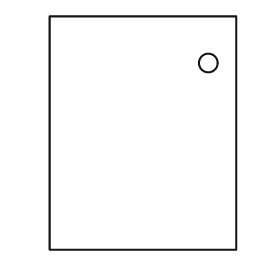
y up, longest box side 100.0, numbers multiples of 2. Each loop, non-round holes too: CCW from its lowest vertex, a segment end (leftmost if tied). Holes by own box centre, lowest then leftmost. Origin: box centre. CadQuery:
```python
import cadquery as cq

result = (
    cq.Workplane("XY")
    .moveTo(-40.0, -50.0)
    .lineTo(40.0, -50.0)
    .lineTo(40.0, 50.0)
    .lineTo(-40.0, 50.0)
    .close()
    .moveTo(28.0, 30.0)
    .circle(4.0)
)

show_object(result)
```